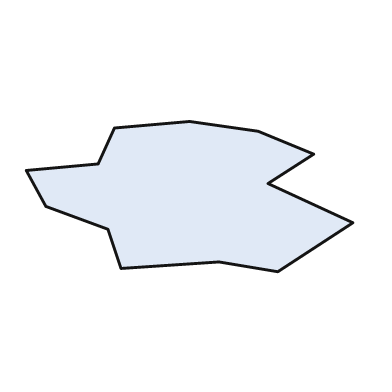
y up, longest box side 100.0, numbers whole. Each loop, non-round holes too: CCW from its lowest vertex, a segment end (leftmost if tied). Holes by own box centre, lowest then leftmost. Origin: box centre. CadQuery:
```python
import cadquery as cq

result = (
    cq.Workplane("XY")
    .moveTo(27.0, -23.0)
    .lineTo(50.0, -8.0)
    .lineTo(24.0, 4.0)
    .lineTo(38.0, 13.0)
    .lineTo(21.0, 20.0)
    .lineTo(0.0, 23.0)
    .lineTo(-23.0, 21.0)
    .lineTo(-28.0, 10.0)
    .lineTo(-50.0, 8.0)
    .lineTo(-44.0, -3.0)
    .lineTo(-25.0, -10.0)
    .lineTo(-21.0, -22.0)
    .lineTo(9.0, -20.0)
    .close()
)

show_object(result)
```